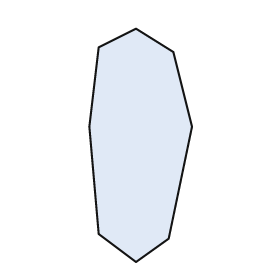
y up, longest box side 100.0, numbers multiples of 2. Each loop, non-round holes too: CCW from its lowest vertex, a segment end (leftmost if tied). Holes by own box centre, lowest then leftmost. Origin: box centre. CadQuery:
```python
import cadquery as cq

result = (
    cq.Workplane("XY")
    .moveTo(-2.0, -50.0)
    .lineTo(12.0, -40.0)
    .lineTo(22.0, 8.0)
    .lineTo(14.0, 40.0)
    .lineTo(-2.0, 50.0)
    .lineTo(-18.0, 42.0)
    .lineTo(-22.0, 8.0)
    .lineTo(-18.0, -38.0)
    .close()
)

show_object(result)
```